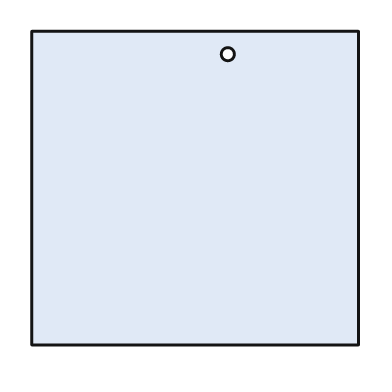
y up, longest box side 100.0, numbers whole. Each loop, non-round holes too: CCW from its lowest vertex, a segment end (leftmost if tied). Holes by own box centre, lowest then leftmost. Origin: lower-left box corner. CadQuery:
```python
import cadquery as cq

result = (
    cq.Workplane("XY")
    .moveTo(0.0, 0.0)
    .lineTo(100.0, 0.0)
    .lineTo(100.0, 96.0)
    .lineTo(0.0, 96.0)
    .close()
    .moveTo(60.0, 89.0)
    .circle(2.0)
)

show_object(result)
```